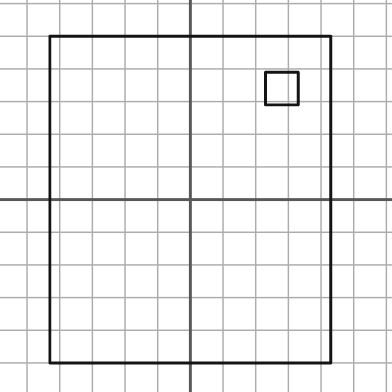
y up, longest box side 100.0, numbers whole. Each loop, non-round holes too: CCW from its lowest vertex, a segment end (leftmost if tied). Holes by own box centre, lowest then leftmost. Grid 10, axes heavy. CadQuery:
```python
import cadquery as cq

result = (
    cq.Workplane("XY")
    .moveTo(-43.0, -50.0)
    .lineTo(43.0, -50.0)
    .lineTo(43.0, 50.0)
    .lineTo(-43.0, 50.0)
    .close()
    .moveTo(23.0, 29.0)
    .lineTo(33.0, 29.0)
    .lineTo(33.0, 39.0)
    .lineTo(23.0, 39.0)
    .close()
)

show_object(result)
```